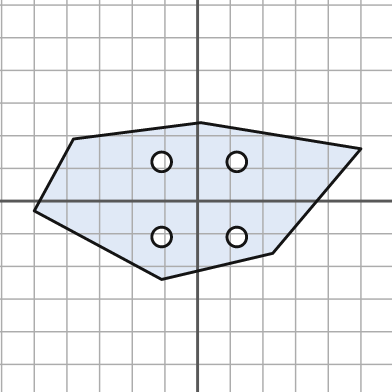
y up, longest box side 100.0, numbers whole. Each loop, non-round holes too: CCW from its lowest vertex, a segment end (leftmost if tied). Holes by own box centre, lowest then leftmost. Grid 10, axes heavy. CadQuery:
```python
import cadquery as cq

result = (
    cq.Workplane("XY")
    .moveTo(-11.0, -24.0)
    .lineTo(23.0, -16.0)
    .lineTo(50.0, 16.0)
    .lineTo(1.0, 24.0)
    .lineTo(-38.0, 19.0)
    .lineTo(-50.0, -3.0)
    .close()
    .moveTo(-11.0, -11.0)
    .circle(3.0)
    .moveTo(12.0, -11.0)
    .circle(3.0)
    .moveTo(-11.0, 12.0)
    .circle(3.0)
    .moveTo(12.0, 12.0)
    .circle(3.0)
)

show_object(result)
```